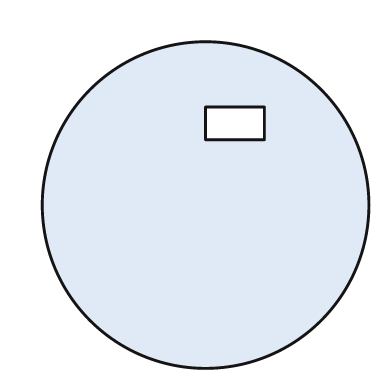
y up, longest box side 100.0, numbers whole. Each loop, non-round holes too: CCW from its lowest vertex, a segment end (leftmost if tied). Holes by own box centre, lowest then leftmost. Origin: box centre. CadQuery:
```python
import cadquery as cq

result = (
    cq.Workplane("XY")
    .moveTo(0.0, 0.0)
    .circle(50.0)
    .moveTo(0.0, 20.0)
    .lineTo(18.0, 20.0)
    .lineTo(18.0, 30.0)
    .lineTo(0.0, 30.0)
    .close()
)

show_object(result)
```